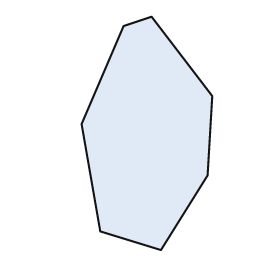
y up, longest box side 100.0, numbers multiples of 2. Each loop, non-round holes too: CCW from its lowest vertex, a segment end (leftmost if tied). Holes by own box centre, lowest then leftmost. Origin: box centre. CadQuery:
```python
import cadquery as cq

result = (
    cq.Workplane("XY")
    .moveTo(6.0, -50.0)
    .lineTo(26.0, -18.0)
    .lineTo(28.0, 16.0)
    .lineTo(2.0, 50.0)
    .lineTo(-10.0, 46.0)
    .lineTo(-28.0, 4.0)
    .lineTo(-20.0, -42.0)
    .close()
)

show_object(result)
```